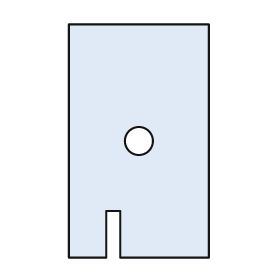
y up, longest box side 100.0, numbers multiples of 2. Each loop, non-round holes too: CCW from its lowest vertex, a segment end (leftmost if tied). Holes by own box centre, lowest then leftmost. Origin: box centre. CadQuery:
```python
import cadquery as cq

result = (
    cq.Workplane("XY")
    .moveTo(-30.0, -50.0)
    .lineTo(-14.0, -50.0)
    .lineTo(-14.0, -30.0)
    .lineTo(-8.0, -30.0)
    .lineTo(-8.0, -50.0)
    .lineTo(30.0, -50.0)
    .lineTo(30.0, 50.0)
    .lineTo(-30.0, 50.0)
    .close()
    .moveTo(0.0, 0.0)
    .circle(6.0)
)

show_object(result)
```